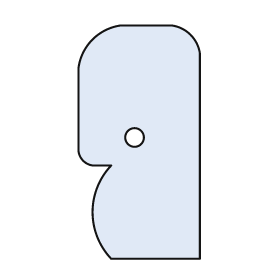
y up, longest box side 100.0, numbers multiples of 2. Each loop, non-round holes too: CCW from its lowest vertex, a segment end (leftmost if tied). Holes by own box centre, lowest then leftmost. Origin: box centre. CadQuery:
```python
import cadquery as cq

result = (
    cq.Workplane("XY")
    .moveTo(-12.0, -50.0)
    .lineTo(26.0, -50.0)
    .lineTo(26.0, 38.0)
    .threePointArc((22.0, 46.0), (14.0, 50.0))
    .lineTo(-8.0, 50.0)
    .threePointArc((-20.0, 44.0), (-26.0, 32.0))
    .lineTo(-26.0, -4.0)
    .threePointArc((-24.0, -8.0), (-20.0, -10.0))
    .lineTo(-12.0, -10.0)
    .threePointArc((-20.0, -30.0), (-12.0, -50.0))
    .close()
    .moveTo(-2.0, 2.0)
    .circle(4.0)
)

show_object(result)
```